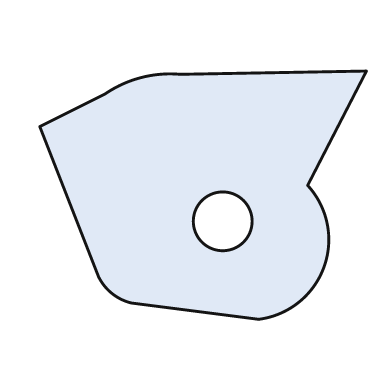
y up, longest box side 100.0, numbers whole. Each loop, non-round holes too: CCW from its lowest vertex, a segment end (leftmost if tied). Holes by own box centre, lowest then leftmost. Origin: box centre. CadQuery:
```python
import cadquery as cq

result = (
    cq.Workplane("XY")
    .moveTo(17.0, -38.0)
    .threePointArc((37.0, -22.0), (32.0, 3.0))
    .lineTo(50.0, 38.0)
    .lineTo(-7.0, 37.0)
    .threePointArc((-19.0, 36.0), (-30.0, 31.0))
    .lineTo(-50.0, 21.0)
    .lineTo(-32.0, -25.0)
    .threePointArc((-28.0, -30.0), (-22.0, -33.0))
    .close()
    .moveTo(6.0, -8.0)
    .circle(9.0)
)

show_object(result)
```